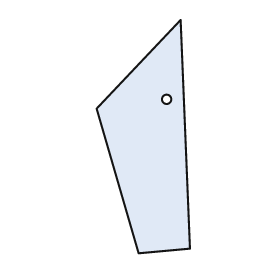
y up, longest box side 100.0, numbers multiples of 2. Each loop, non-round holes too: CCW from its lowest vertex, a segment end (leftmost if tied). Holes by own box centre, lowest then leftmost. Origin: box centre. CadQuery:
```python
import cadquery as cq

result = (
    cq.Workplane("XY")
    .moveTo(-2.0, -50.0)
    .lineTo(20.0, -48.0)
    .lineTo(16.0, 50.0)
    .lineTo(-20.0, 12.0)
    .close()
    .moveTo(10.0, 16.0)
    .circle(2.0)
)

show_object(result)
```